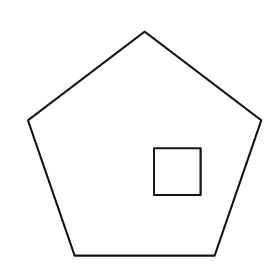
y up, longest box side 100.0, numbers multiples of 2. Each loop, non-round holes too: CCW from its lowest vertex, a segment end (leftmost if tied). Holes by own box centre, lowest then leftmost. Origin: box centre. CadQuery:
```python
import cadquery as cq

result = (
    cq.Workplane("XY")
    .moveTo(-30.0, -48.0)
    .lineTo(30.0, -48.0)
    .lineTo(50.0, 10.0)
    .lineTo(0.0, 48.0)
    .lineTo(-50.0, 10.0)
    .close()
    .moveTo(4.0, -22.0)
    .lineTo(24.0, -22.0)
    .lineTo(24.0, -2.0)
    .lineTo(4.0, -2.0)
    .close()
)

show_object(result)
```